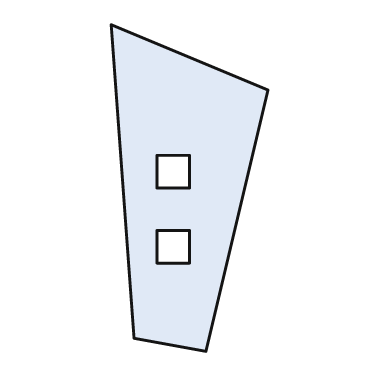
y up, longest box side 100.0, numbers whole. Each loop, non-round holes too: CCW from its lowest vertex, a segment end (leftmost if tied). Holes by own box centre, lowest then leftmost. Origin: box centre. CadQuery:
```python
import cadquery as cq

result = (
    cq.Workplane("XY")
    .moveTo(5.0, -50.0)
    .lineTo(24.0, 30.0)
    .lineTo(-24.0, 50.0)
    .lineTo(-17.0, -46.0)
    .close()
    .moveTo(-10.0, -23.0)
    .lineTo(0.0, -23.0)
    .lineTo(0.0, -13.0)
    .lineTo(-10.0, -13.0)
    .close()
    .moveTo(-10.0, 0.0)
    .lineTo(0.0, 0.0)
    .lineTo(0.0, 10.0)
    .lineTo(-10.0, 10.0)
    .close()
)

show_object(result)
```